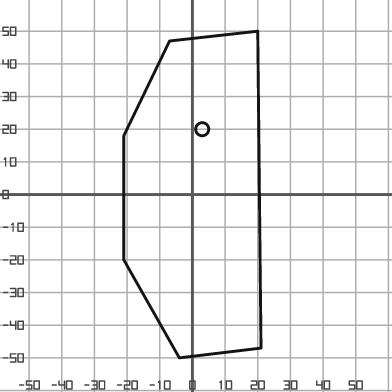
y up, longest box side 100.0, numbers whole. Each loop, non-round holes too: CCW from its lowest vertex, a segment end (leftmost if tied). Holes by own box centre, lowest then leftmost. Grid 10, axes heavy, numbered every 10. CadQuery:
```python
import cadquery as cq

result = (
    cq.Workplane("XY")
    .moveTo(-4.0, -50.0)
    .lineTo(21.0, -47.0)
    .lineTo(20.0, 50.0)
    .lineTo(-7.0, 47.0)
    .lineTo(-21.0, 18.0)
    .lineTo(-21.0, -20.0)
    .close()
    .moveTo(3.0, 20.0)
    .circle(2.0)
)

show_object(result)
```